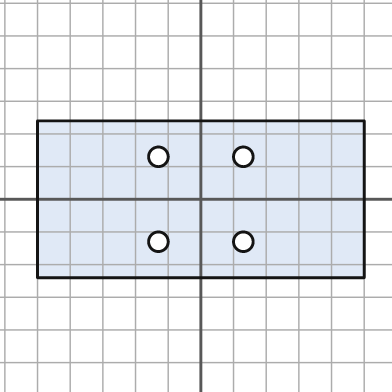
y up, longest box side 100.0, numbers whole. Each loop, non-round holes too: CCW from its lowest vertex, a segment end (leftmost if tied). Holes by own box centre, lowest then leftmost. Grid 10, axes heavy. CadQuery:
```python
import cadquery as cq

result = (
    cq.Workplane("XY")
    .moveTo(-50.0, -24.0)
    .lineTo(50.0, -24.0)
    .lineTo(50.0, 24.0)
    .lineTo(-50.0, 24.0)
    .close()
    .moveTo(-13.0, -13.0)
    .circle(3.0)
    .moveTo(13.0, -13.0)
    .circle(3.0)
    .moveTo(-13.0, 13.0)
    .circle(3.0)
    .moveTo(13.0, 13.0)
    .circle(3.0)
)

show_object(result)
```